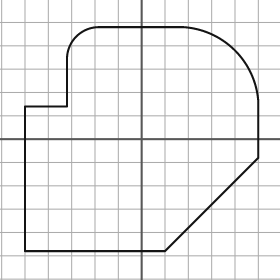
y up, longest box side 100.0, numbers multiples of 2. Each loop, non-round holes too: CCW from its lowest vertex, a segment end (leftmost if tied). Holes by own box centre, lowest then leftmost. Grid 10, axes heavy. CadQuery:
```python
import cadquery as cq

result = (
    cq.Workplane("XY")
    .moveTo(-50.0, -48.0)
    .lineTo(10.0, -48.0)
    .lineTo(50.0, -8.0)
    .lineTo(50.0, 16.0)
    .threePointArc((40.0, 38.0), (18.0, 48.0))
    .lineTo(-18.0, 48.0)
    .threePointArc((-28.0, 44.0), (-32.0, 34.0))
    .lineTo(-32.0, 14.0)
    .lineTo(-50.0, 14.0)
    .close()
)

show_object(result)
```